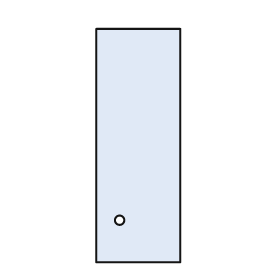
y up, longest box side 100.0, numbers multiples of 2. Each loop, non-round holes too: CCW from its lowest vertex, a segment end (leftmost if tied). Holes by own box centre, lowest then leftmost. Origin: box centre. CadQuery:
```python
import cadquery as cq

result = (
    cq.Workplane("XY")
    .moveTo(-18.0, -50.0)
    .lineTo(18.0, -50.0)
    .lineTo(18.0, 50.0)
    .lineTo(-18.0, 50.0)
    .close()
    .moveTo(-8.0, -32.0)
    .circle(2.0)
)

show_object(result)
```